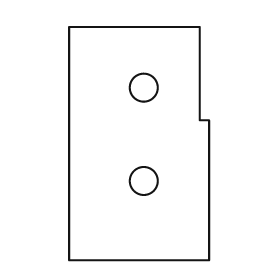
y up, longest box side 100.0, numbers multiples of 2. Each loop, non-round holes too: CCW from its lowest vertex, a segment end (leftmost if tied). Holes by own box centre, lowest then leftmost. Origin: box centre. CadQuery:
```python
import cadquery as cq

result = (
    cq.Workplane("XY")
    .moveTo(-30.0, -50.0)
    .lineTo(30.0, -50.0)
    .lineTo(30.0, 10.0)
    .lineTo(26.0, 10.0)
    .lineTo(26.0, 50.0)
    .lineTo(-30.0, 50.0)
    .close()
    .moveTo(2.0, -16.0)
    .circle(6.0)
    .moveTo(2.0, 24.0)
    .circle(6.0)
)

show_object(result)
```